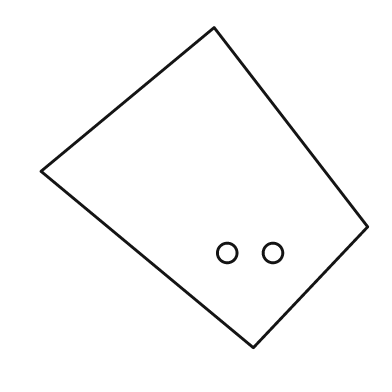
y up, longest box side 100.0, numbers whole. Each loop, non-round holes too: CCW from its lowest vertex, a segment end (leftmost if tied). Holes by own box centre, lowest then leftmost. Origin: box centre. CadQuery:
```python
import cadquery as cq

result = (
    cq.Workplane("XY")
    .moveTo(15.0, -49.0)
    .lineTo(50.0, -12.0)
    .lineTo(3.0, 49.0)
    .lineTo(-50.0, 5.0)
    .close()
    .moveTo(7.0, -20.0)
    .circle(3.0)
    .moveTo(21.0, -20.0)
    .circle(3.0)
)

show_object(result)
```